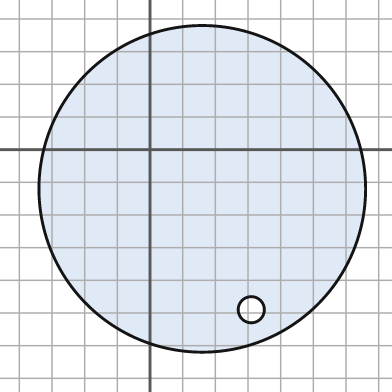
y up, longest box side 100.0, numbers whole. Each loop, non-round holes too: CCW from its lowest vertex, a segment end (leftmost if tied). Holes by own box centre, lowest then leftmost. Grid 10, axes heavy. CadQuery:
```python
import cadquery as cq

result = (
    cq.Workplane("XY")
    .moveTo(16.0, -12.0)
    .circle(50.0)
    .moveTo(31.0, -49.0)
    .circle(4.0)
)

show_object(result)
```